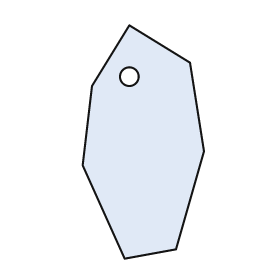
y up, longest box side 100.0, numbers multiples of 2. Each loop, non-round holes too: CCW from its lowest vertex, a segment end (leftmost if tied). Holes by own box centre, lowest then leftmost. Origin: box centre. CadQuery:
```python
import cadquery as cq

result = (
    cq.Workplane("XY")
    .moveTo(-8.0, -50.0)
    .lineTo(14.0, -46.0)
    .lineTo(26.0, -4.0)
    .lineTo(20.0, 34.0)
    .lineTo(-6.0, 50.0)
    .lineTo(-22.0, 24.0)
    .lineTo(-26.0, -10.0)
    .close()
    .moveTo(-6.0, 28.0)
    .circle(4.0)
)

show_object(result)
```